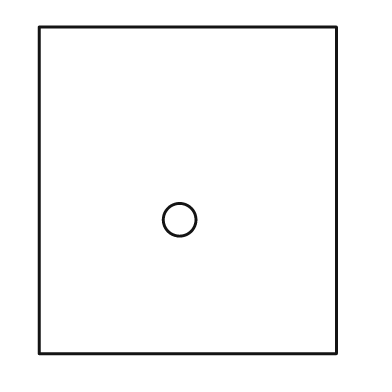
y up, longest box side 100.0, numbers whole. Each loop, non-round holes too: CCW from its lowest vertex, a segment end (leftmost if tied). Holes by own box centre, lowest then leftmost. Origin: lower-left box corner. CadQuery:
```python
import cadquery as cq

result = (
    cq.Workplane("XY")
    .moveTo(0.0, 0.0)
    .lineTo(91.0, 0.0)
    .lineTo(91.0, 100.0)
    .lineTo(0.0, 100.0)
    .close()
    .moveTo(43.0, 41.0)
    .circle(5.0)
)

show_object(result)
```